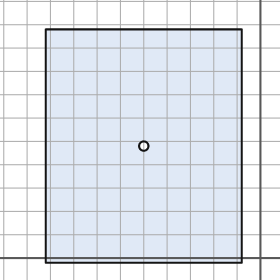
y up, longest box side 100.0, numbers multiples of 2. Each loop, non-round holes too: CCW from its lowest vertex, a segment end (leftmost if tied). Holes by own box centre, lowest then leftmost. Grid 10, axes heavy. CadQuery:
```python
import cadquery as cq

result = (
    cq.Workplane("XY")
    .moveTo(-92.0, -2.0)
    .lineTo(-8.0, -2.0)
    .lineTo(-8.0, 98.0)
    .lineTo(-92.0, 98.0)
    .close()
    .moveTo(-50.0, 48.0)
    .circle(2.0)
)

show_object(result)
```